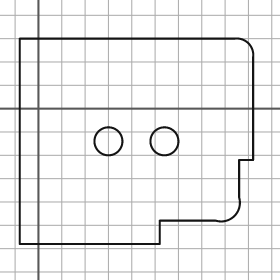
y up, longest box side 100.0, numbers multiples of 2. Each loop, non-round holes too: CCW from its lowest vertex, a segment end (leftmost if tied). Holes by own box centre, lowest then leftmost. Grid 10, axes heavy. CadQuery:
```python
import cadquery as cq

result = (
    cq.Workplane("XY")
    .moveTo(-8.0, -58.0)
    .lineTo(52.0, -58.0)
    .lineTo(52.0, -48.0)
    .lineTo(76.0, -48.0)
    .threePointArc((84.0, -46.0), (86.0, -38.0))
    .lineTo(86.0, -22.0)
    .lineTo(92.0, -22.0)
    .lineTo(92.0, 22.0)
    .threePointArc((90.0, 28.0), (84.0, 30.0))
    .lineTo(-8.0, 30.0)
    .close()
    .moveTo(30.0, -14.0)
    .circle(6.0)
    .moveTo(54.0, -14.0)
    .circle(6.0)
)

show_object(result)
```